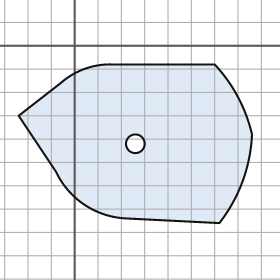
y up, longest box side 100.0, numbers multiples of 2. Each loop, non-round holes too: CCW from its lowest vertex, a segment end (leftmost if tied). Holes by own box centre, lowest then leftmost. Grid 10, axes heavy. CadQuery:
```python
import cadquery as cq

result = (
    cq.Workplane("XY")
    .moveTo(62.0, -76.0)
    .threePointArc((72.0, -58.0), (76.0, -38.0))
    .threePointArc((70.0, -22.0), (60.0, -8.0))
    .lineTo(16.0, -8.0)
    .threePointArc((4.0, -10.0), (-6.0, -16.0))
    .lineTo(-24.0, -30.0)
    .lineTo(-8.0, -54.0)
    .threePointArc((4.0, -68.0), (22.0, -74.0))
    .close()
    .moveTo(26.0, -42.0)
    .circle(4.0)
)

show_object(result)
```